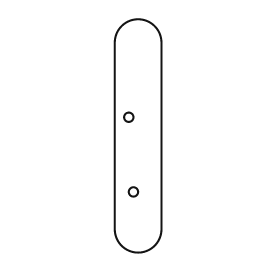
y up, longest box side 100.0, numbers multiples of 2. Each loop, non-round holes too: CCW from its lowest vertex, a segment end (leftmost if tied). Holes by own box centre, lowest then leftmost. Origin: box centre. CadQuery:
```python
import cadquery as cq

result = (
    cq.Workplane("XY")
    .moveTo(-10.0, -40.0)
    .threePointArc((0.0, -50.0), (10.0, -40.0))
    .lineTo(10.0, 40.0)
    .threePointArc((0.0, 50.0), (-10.0, 40.0))
    .close()
    .moveTo(-2.0, -24.0)
    .circle(2.0)
    .moveTo(-4.0, 8.0)
    .circle(2.0)
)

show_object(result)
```